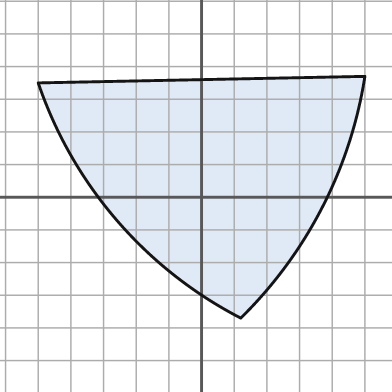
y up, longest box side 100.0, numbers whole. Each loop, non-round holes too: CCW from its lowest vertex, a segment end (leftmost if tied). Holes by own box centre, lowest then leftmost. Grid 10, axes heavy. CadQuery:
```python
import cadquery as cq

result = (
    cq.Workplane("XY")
    .moveTo(12.0, -37.0)
    .threePointArc((37.0, -3.0), (50.0, 37.0))
    .lineTo(-50.0, 35.0)
    .threePointArc((-26.0, -7.0), (12.0, -37.0))
    .close()
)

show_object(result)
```